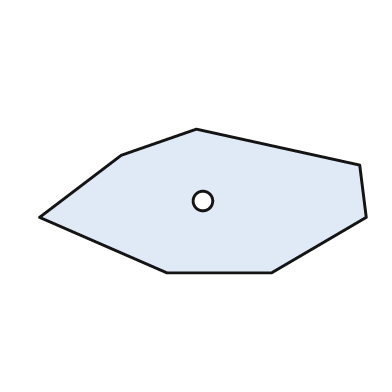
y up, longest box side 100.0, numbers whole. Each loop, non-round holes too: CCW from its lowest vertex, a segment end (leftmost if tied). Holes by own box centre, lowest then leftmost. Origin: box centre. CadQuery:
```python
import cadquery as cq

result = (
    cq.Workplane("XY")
    .moveTo(-11.0, -22.0)
    .lineTo(21.0, -22.0)
    .lineTo(50.0, -5.0)
    .lineTo(48.0, 11.0)
    .lineTo(-2.0, 22.0)
    .lineTo(-25.0, 14.0)
    .lineTo(-50.0, -5.0)
    .close()
    .moveTo(0.0, 0.0)
    .circle(3.0)
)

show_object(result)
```